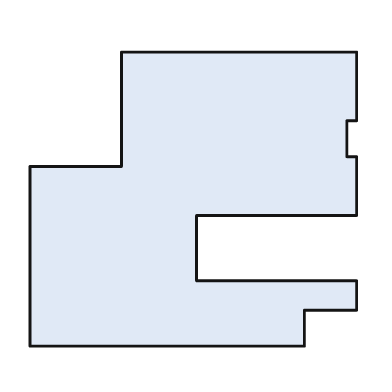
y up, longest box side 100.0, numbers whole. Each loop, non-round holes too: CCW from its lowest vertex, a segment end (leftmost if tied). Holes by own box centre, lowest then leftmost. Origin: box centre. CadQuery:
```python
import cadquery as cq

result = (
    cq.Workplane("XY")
    .moveTo(-50.0, -45.0)
    .lineTo(34.0, -45.0)
    .lineTo(34.0, -34.0)
    .lineTo(50.0, -34.0)
    .lineTo(50.0, -25.0)
    .lineTo(1.0, -25.0)
    .lineTo(1.0, -5.0)
    .lineTo(50.0, -5.0)
    .lineTo(50.0, 13.0)
    .lineTo(47.0, 13.0)
    .lineTo(47.0, 24.0)
    .lineTo(50.0, 24.0)
    .lineTo(50.0, 45.0)
    .lineTo(-22.0, 45.0)
    .lineTo(-22.0, 10.0)
    .lineTo(-50.0, 10.0)
    .close()
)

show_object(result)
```